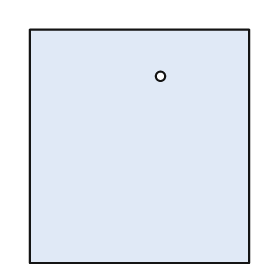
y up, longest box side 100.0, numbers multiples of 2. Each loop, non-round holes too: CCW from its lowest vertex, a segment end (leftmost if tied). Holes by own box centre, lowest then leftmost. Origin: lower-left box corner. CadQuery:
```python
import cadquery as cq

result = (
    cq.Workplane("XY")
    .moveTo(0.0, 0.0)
    .lineTo(94.0, 0.0)
    .lineTo(94.0, 100.0)
    .lineTo(0.0, 100.0)
    .close()
    .moveTo(56.0, 80.0)
    .circle(2.0)
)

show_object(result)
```